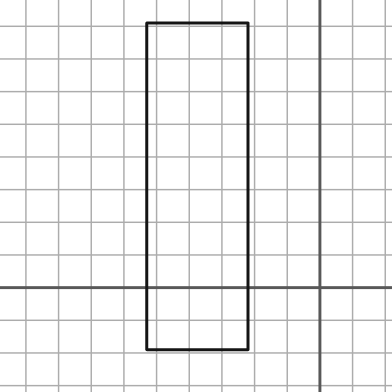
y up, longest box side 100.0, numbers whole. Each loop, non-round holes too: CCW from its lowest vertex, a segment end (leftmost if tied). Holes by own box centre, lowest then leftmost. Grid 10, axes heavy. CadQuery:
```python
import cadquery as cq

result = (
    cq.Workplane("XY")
    .moveTo(-53.0, -19.0)
    .lineTo(-22.0, -19.0)
    .lineTo(-22.0, 81.0)
    .lineTo(-53.0, 81.0)
    .close()
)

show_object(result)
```